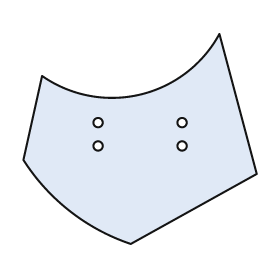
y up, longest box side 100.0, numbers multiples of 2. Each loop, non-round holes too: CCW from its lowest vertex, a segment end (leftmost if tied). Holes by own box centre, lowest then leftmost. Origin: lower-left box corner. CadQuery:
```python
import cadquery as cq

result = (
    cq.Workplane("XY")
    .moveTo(46.0, 0.0)
    .lineTo(100.0, 30.0)
    .lineTo(84.0, 90.0)
    .threePointArc((50.0, 64.0), (8.0, 72.0))
    .lineTo(0.0, 36.0)
    .threePointArc((20.0, 14.0), (46.0, 0.0))
    .close()
    .moveTo(32.0, 42.0)
    .circle(2.0)
    .moveTo(68.0, 42.0)
    .circle(2.0)
    .moveTo(32.0, 52.0)
    .circle(2.0)
    .moveTo(68.0, 52.0)
    .circle(2.0)
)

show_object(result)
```